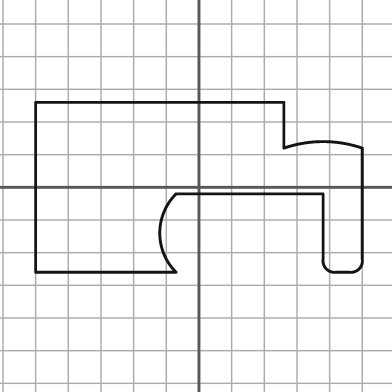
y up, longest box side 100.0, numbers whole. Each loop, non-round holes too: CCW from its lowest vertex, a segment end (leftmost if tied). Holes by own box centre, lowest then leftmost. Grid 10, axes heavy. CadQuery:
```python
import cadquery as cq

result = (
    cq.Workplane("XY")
    .moveTo(-50.0, -26.0)
    .lineTo(-7.0, -26.0)
    .threePointArc((-12.0, -14.0), (-7.0, -2.0))
    .lineTo(38.0, -2.0)
    .lineTo(38.0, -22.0)
    .threePointArc((39.0, -25.0), (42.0, -26.0))
    .lineTo(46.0, -26.0)
    .threePointArc((49.0, -25.0), (50.0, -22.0))
    .lineTo(50.0, 12.0)
    .threePointArc((38.0, 14.0), (26.0, 12.0))
    .lineTo(26.0, 26.0)
    .lineTo(-50.0, 26.0)
    .close()
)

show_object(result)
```